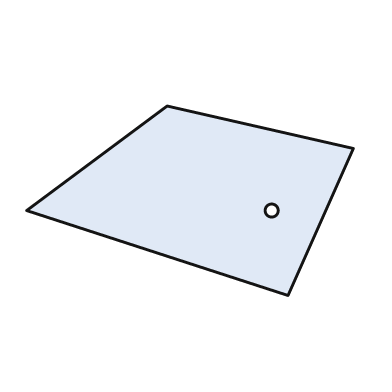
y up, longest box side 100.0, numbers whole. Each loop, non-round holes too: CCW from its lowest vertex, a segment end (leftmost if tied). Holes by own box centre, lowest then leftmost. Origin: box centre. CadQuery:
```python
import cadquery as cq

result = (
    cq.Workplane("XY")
    .moveTo(30.0, -29.0)
    .lineTo(50.0, 16.0)
    .lineTo(-7.0, 29.0)
    .lineTo(-50.0, -3.0)
    .close()
    .moveTo(25.0, -3.0)
    .circle(2.0)
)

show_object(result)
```